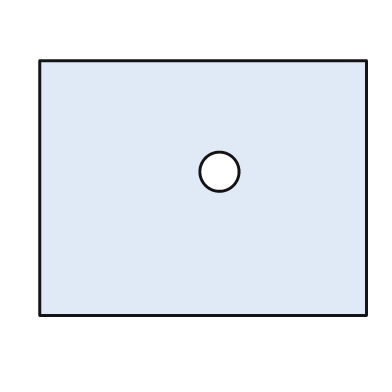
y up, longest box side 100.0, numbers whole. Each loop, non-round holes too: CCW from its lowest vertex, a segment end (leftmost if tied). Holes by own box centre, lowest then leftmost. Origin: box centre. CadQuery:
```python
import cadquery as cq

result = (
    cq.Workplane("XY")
    .moveTo(-50.0, -39.0)
    .lineTo(50.0, -39.0)
    .lineTo(50.0, 39.0)
    .lineTo(-50.0, 39.0)
    .close()
    .moveTo(5.0, 5.0)
    .circle(6.0)
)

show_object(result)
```